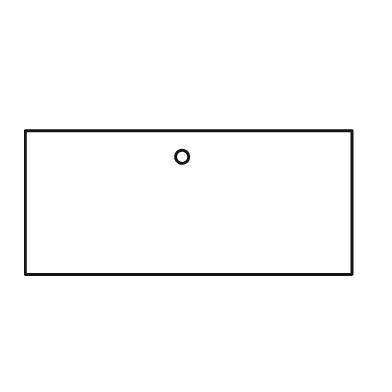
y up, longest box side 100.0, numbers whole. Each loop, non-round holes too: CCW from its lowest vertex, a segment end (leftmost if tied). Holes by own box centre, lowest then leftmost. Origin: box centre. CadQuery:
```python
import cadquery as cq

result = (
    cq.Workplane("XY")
    .moveTo(-50.0, -22.0)
    .lineTo(50.0, -22.0)
    .lineTo(50.0, 22.0)
    .lineTo(-50.0, 22.0)
    .close()
    .moveTo(-2.0, 14.0)
    .circle(2.0)
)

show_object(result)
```